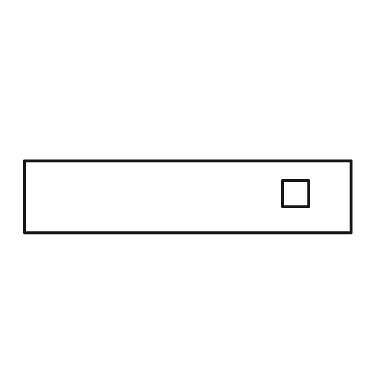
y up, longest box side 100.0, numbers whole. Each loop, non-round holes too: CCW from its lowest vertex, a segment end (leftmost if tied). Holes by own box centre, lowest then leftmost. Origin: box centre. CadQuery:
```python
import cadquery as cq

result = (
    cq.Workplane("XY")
    .moveTo(-50.0, -11.0)
    .lineTo(50.0, -11.0)
    .lineTo(50.0, 11.0)
    .lineTo(-50.0, 11.0)
    .close()
    .moveTo(29.0, -3.0)
    .lineTo(37.0, -3.0)
    .lineTo(37.0, 5.0)
    .lineTo(29.0, 5.0)
    .close()
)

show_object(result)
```